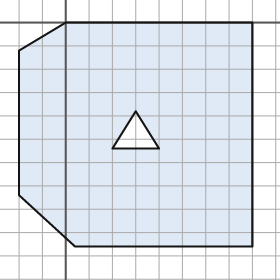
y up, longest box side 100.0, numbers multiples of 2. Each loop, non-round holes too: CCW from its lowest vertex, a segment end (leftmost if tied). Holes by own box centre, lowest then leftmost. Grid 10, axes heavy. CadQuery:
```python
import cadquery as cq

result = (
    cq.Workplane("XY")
    .moveTo(4.0, -96.0)
    .lineTo(80.0, -96.0)
    .lineTo(80.0, 0.0)
    .lineTo(0.0, 0.0)
    .lineTo(-20.0, -12.0)
    .lineTo(-20.0, -74.0)
    .close()
    .moveTo(20.0, -54.0)
    .lineTo(40.0, -54.0)
    .lineTo(30.0, -38.0)
    .close()
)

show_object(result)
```